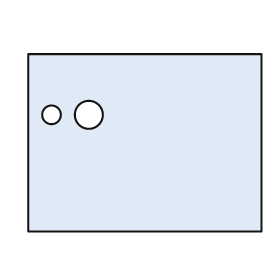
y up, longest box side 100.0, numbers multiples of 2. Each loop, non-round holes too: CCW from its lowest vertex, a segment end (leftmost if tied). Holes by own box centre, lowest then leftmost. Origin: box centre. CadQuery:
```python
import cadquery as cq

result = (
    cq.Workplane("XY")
    .moveTo(-50.0, -38.0)
    .lineTo(50.0, -38.0)
    .lineTo(50.0, 38.0)
    .lineTo(-50.0, 38.0)
    .close()
    .moveTo(-40.0, 12.0)
    .circle(4.0)
    .moveTo(-24.0, 12.0)
    .circle(6.0)
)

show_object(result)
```